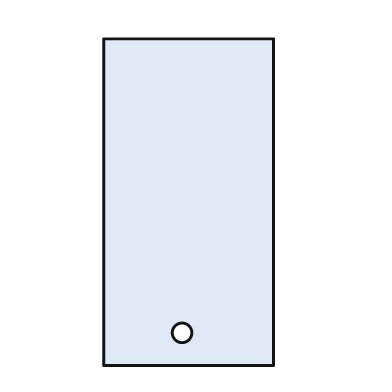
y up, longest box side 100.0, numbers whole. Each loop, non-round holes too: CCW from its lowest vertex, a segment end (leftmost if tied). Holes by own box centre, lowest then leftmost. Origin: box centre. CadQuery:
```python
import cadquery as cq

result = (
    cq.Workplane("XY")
    .moveTo(-26.0, -50.0)
    .lineTo(26.0, -50.0)
    .lineTo(26.0, 50.0)
    .lineTo(-26.0, 50.0)
    .close()
    .moveTo(-2.0, -40.0)
    .circle(3.0)
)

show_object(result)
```